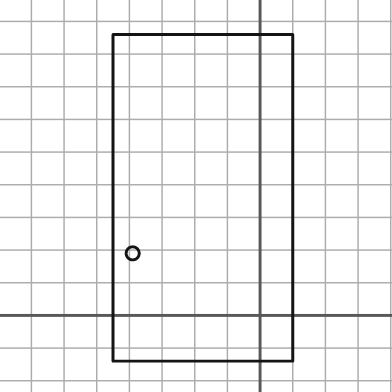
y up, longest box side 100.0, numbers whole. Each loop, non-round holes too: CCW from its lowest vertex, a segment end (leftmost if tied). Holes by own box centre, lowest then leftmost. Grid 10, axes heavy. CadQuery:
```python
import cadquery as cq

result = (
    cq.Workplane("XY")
    .moveTo(-45.0, -14.0)
    .lineTo(10.0, -14.0)
    .lineTo(10.0, 86.0)
    .lineTo(-45.0, 86.0)
    .close()
    .moveTo(-39.0, 19.0)
    .circle(2.0)
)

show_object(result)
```